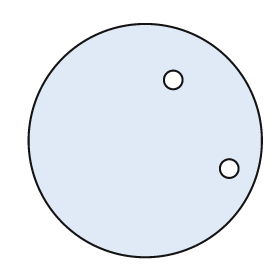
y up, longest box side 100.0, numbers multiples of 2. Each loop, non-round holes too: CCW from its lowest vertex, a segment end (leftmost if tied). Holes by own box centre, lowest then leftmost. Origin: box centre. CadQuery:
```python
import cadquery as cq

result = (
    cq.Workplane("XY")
    .moveTo(0.0, 0.0)
    .circle(50.0)
    .moveTo(36.0, -12.0)
    .circle(4.0)
    .moveTo(12.0, 26.0)
    .circle(4.0)
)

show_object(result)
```